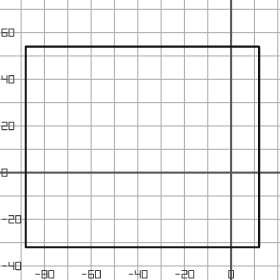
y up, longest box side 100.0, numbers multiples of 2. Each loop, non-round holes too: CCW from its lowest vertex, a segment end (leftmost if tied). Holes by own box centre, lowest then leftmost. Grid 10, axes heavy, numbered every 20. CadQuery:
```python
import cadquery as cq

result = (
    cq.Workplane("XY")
    .moveTo(-88.0, -32.0)
    .lineTo(12.0, -32.0)
    .lineTo(12.0, 54.0)
    .lineTo(-88.0, 54.0)
    .close()
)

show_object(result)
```